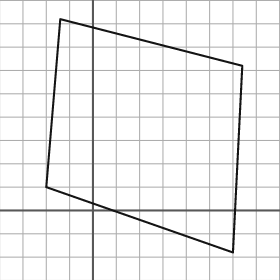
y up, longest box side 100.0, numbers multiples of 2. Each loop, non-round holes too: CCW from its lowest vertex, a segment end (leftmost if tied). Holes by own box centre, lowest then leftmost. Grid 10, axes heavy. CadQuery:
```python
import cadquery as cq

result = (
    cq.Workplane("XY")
    .moveTo(60.0, -18.0)
    .lineTo(64.0, 62.0)
    .lineTo(-14.0, 82.0)
    .lineTo(-20.0, 10.0)
    .close()
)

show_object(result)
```